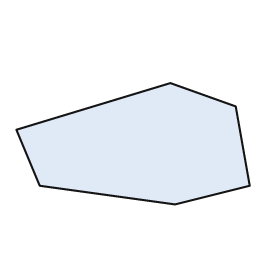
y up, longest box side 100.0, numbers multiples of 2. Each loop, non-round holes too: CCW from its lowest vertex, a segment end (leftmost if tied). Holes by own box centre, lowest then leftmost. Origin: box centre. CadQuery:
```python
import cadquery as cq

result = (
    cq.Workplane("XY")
    .moveTo(18.0, -26.0)
    .lineTo(50.0, -18.0)
    .lineTo(44.0, 16.0)
    .lineTo(16.0, 26.0)
    .lineTo(-50.0, 6.0)
    .lineTo(-40.0, -18.0)
    .close()
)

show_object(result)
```